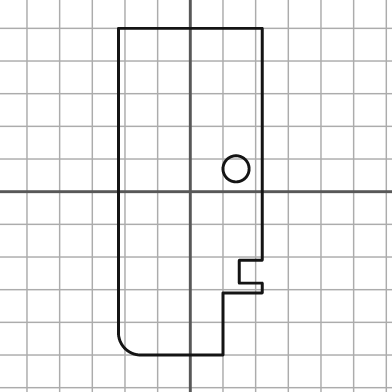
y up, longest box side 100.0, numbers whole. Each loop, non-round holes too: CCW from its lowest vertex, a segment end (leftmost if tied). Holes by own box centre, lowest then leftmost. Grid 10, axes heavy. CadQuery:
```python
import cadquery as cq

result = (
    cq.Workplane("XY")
    .moveTo(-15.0, -50.0)
    .lineTo(10.0, -50.0)
    .lineTo(10.0, -31.0)
    .lineTo(22.0, -31.0)
    .lineTo(22.0, -28.0)
    .lineTo(15.0, -28.0)
    .lineTo(15.0, -21.0)
    .lineTo(22.0, -21.0)
    .lineTo(22.0, 50.0)
    .lineTo(-22.0, 50.0)
    .lineTo(-22.0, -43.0)
    .threePointArc((-20.0, -48.0), (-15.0, -50.0))
    .close()
    .moveTo(14.0, 7.0)
    .circle(4.0)
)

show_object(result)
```